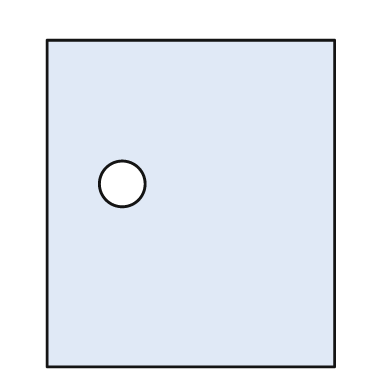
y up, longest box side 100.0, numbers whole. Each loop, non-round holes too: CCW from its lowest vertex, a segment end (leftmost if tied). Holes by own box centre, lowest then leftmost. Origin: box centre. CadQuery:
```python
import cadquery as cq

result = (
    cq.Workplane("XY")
    .moveTo(-44.0, -50.0)
    .lineTo(44.0, -50.0)
    .lineTo(44.0, 50.0)
    .lineTo(-44.0, 50.0)
    .close()
    .moveTo(-21.0, 6.0)
    .circle(7.0)
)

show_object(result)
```